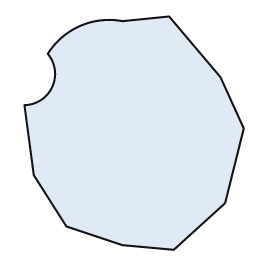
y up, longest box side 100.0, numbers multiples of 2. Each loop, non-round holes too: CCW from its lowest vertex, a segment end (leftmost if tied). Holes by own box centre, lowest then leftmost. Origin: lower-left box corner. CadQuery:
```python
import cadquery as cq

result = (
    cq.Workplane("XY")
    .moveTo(64.0, 0.0)
    .lineTo(86.0, 20.0)
    .lineTo(94.0, 52.0)
    .lineTo(84.0, 74.0)
    .lineTo(62.0, 100.0)
    .lineTo(42.0, 98.0)
    .threePointArc((24.0, 96.0), (10.0, 84.0))
    .threePointArc((12.0, 70.0), (0.0, 62.0))
    .lineTo(4.0, 32.0)
    .lineTo(18.0, 10.0)
    .lineTo(42.0, 2.0)
    .close()
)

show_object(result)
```